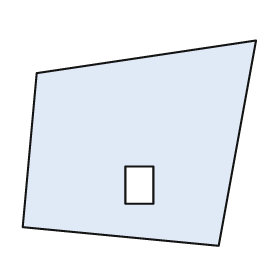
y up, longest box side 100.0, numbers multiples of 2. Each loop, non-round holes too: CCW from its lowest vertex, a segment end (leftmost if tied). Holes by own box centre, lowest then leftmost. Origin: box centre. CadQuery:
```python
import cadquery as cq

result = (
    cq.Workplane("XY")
    .moveTo(34.0, -44.0)
    .lineTo(50.0, 44.0)
    .lineTo(-44.0, 30.0)
    .lineTo(-50.0, -36.0)
    .close()
    .moveTo(-6.0, -26.0)
    .lineTo(6.0, -26.0)
    .lineTo(6.0, -10.0)
    .lineTo(-6.0, -10.0)
    .close()
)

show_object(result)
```